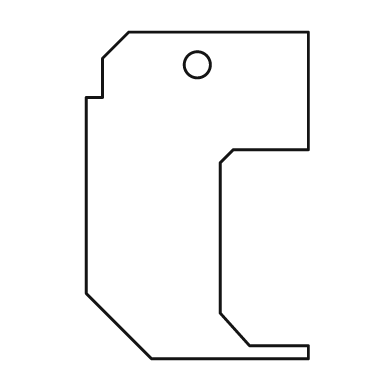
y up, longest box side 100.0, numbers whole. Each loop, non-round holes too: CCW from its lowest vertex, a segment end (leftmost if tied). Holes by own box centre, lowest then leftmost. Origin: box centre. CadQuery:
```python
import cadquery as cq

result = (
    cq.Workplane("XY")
    .moveTo(-14.0, -50.0)
    .lineTo(34.0, -50.0)
    .lineTo(34.0, -46.0)
    .lineTo(16.0, -46.0)
    .lineTo(7.0, -36.0)
    .lineTo(7.0, 10.0)
    .lineTo(11.0, 14.0)
    .lineTo(34.0, 14.0)
    .lineTo(34.0, 50.0)
    .lineTo(-21.0, 50.0)
    .lineTo(-29.0, 42.0)
    .lineTo(-29.0, 30.0)
    .lineTo(-34.0, 30.0)
    .lineTo(-34.0, -30.0)
    .close()
    .moveTo(0.0, 40.0)
    .circle(4.0)
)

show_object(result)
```